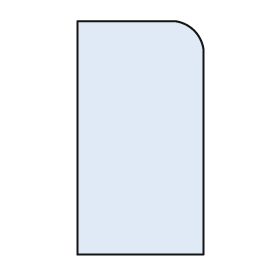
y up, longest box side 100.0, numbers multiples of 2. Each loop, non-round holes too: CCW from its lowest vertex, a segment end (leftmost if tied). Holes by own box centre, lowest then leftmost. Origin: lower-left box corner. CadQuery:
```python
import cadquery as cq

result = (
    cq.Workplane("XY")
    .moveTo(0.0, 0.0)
    .lineTo(54.0, 0.0)
    .lineTo(54.0, 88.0)
    .threePointArc((50.0, 96.0), (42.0, 100.0))
    .lineTo(0.0, 100.0)
    .close()
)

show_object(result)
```